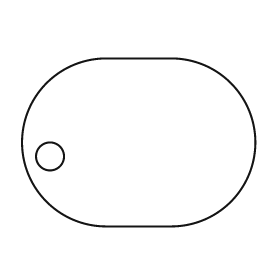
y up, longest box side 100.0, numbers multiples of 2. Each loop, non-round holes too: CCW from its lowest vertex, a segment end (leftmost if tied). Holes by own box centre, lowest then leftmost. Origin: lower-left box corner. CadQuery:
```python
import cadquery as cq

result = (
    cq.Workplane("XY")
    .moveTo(36.0, 0.0)
    .lineTo(64.0, 0.0)
    .threePointArc((100.0, 36.0), (64.0, 72.0))
    .lineTo(36.0, 72.0)
    .threePointArc((0.0, 36.0), (36.0, 0.0))
    .close()
    .moveTo(12.0, 30.0)
    .circle(6.0)
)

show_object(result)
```